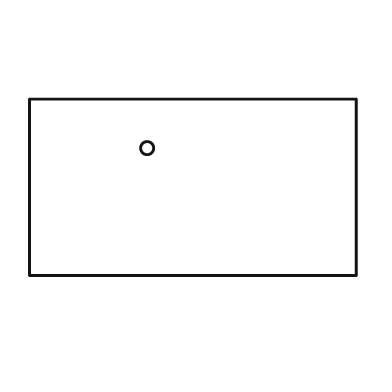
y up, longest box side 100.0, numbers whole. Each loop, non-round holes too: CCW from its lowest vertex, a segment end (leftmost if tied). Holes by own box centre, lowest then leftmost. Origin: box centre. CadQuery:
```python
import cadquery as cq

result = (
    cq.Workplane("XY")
    .moveTo(-50.0, -27.0)
    .lineTo(50.0, -27.0)
    .lineTo(50.0, 27.0)
    .lineTo(-50.0, 27.0)
    .close()
    .moveTo(-14.0, 12.0)
    .circle(2.0)
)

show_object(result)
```